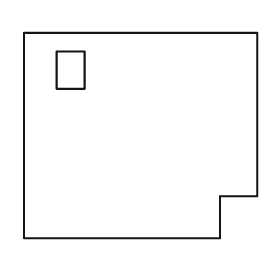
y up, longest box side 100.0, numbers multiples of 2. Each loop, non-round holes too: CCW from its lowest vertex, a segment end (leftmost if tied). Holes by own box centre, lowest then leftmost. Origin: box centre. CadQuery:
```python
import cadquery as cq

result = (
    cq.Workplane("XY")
    .moveTo(-50.0, -44.0)
    .lineTo(34.0, -44.0)
    .lineTo(34.0, -26.0)
    .lineTo(50.0, -26.0)
    .lineTo(50.0, 44.0)
    .lineTo(-50.0, 44.0)
    .close()
    .moveTo(-36.0, 20.0)
    .lineTo(-24.0, 20.0)
    .lineTo(-24.0, 36.0)
    .lineTo(-36.0, 36.0)
    .close()
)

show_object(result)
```